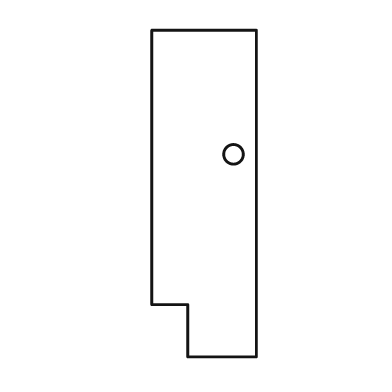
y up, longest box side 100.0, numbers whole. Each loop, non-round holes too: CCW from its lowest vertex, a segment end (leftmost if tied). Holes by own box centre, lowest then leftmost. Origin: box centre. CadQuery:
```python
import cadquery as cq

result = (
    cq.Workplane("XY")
    .moveTo(-5.0, -50.0)
    .lineTo(16.0, -50.0)
    .lineTo(16.0, 50.0)
    .lineTo(-16.0, 50.0)
    .lineTo(-16.0, -34.0)
    .lineTo(-5.0, -34.0)
    .close()
    .moveTo(9.0, 12.0)
    .circle(3.0)
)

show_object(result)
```